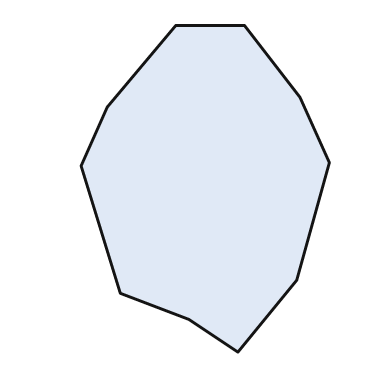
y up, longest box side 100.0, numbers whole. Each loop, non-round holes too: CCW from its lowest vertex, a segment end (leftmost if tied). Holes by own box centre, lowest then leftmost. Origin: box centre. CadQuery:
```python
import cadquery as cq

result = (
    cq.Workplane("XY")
    .moveTo(10.0, -50.0)
    .lineTo(28.0, -28.0)
    .lineTo(38.0, 8.0)
    .lineTo(29.0, 28.0)
    .lineTo(12.0, 50.0)
    .lineTo(-9.0, 50.0)
    .lineTo(-30.0, 25.0)
    .lineTo(-38.0, 7.0)
    .lineTo(-26.0, -32.0)
    .lineTo(-5.0, -40.0)
    .close()
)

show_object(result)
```